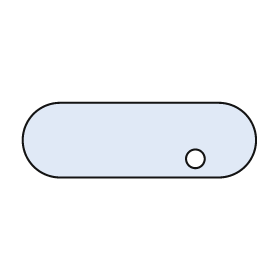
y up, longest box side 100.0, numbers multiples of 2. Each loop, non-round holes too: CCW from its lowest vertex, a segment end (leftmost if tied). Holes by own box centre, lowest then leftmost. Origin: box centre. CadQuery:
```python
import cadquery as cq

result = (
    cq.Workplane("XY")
    .moveTo(-34.0, -16.0)
    .lineTo(34.0, -16.0)
    .threePointArc((50.0, 0.0), (34.0, 16.0))
    .lineTo(-34.0, 16.0)
    .threePointArc((-50.0, 0.0), (-34.0, -16.0))
    .close()
    .moveTo(24.0, -8.0)
    .circle(4.0)
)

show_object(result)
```